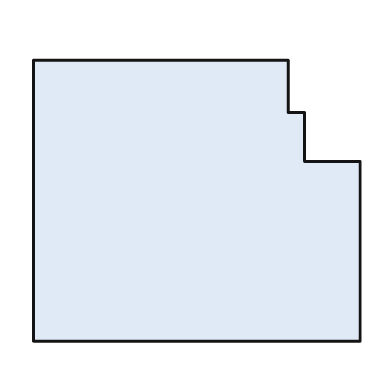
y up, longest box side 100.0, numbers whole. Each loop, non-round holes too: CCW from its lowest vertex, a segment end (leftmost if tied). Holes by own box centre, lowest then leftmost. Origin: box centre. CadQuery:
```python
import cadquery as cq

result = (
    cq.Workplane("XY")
    .moveTo(-50.0, -43.0)
    .lineTo(50.0, -43.0)
    .lineTo(50.0, 12.0)
    .lineTo(33.0, 12.0)
    .lineTo(33.0, 27.0)
    .lineTo(28.0, 27.0)
    .lineTo(28.0, 43.0)
    .lineTo(-50.0, 43.0)
    .close()
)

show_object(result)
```